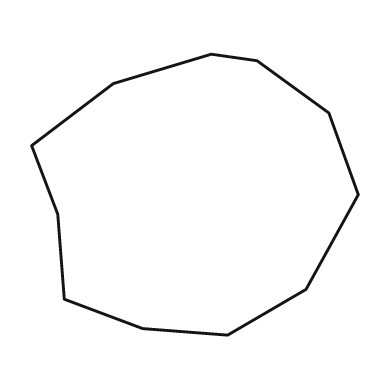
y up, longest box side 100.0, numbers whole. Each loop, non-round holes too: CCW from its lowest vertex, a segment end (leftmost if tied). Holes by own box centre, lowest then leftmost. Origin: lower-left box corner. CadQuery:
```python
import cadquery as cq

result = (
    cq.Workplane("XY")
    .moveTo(60.0, 0.0)
    .lineTo(84.0, 14.0)
    .lineTo(100.0, 43.0)
    .lineTo(91.0, 68.0)
    .lineTo(69.0, 84.0)
    .lineTo(55.0, 86.0)
    .lineTo(25.0, 77.0)
    .lineTo(0.0, 58.0)
    .lineTo(8.0, 37.0)
    .lineTo(10.0, 11.0)
    .lineTo(34.0, 2.0)
    .close()
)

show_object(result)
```